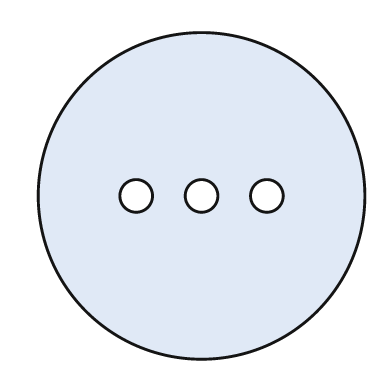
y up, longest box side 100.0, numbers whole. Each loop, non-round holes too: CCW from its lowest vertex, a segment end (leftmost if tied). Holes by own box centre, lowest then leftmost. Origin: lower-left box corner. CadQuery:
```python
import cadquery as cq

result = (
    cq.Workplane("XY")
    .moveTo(50.0, 50.0)
    .circle(50.0)
    .moveTo(30.0, 50.0)
    .circle(5.0)
    .moveTo(50.0, 50.0)
    .circle(5.0)
    .moveTo(70.0, 50.0)
    .circle(5.0)
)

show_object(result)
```